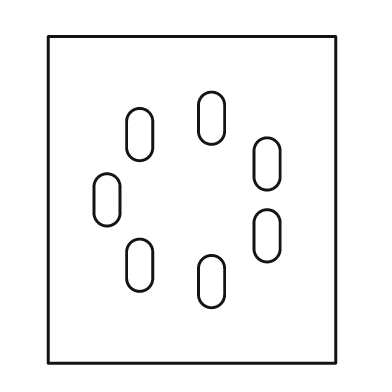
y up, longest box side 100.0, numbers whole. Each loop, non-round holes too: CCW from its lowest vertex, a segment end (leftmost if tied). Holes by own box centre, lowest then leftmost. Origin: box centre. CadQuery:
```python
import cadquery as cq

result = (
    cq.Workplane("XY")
    .moveTo(-44.0, -50.0)
    .lineTo(44.0, -50.0)
    .lineTo(44.0, 50.0)
    .lineTo(-44.0, 50.0)
    .close()
    .moveTo(2.0, -29.0)
    .threePointArc((6.0, -33.0), (10.0, -29.0))
    .lineTo(10.0, -21.0)
    .threePointArc((6.0, -17.0), (2.0, -21.0))
    .close()
    .moveTo(-20.0, -24.0)
    .threePointArc((-16.0, -28.0), (-12.0, -24.0))
    .lineTo(-12.0, -16.0)
    .threePointArc((-16.0, -12.0), (-20.0, -16.0))
    .close()
    .moveTo(19.0, -15.0)
    .threePointArc((23.0, -19.0), (27.0, -15.0))
    .lineTo(27.0, -7.0)
    .threePointArc((23.0, -3.0), (19.0, -7.0))
    .close()
    .moveTo(-30.0, -4.0)
    .threePointArc((-26.0, -8.0), (-22.0, -4.0))
    .lineTo(-22.0, 4.0)
    .threePointArc((-26.0, 8.0), (-30.0, 4.0))
    .close()
    .moveTo(19.0, 7.0)
    .threePointArc((23.0, 3.0), (27.0, 7.0))
    .lineTo(27.0, 15.0)
    .threePointArc((23.0, 19.0), (19.0, 15.0))
    .close()
    .moveTo(-20.0, 16.0)
    .threePointArc((-16.0, 12.0), (-12.0, 16.0))
    .lineTo(-12.0, 24.0)
    .threePointArc((-16.0, 28.0), (-20.0, 24.0))
    .close()
    .moveTo(2.0, 21.0)
    .threePointArc((6.0, 17.0), (10.0, 21.0))
    .lineTo(10.0, 29.0)
    .threePointArc((6.0, 33.0), (2.0, 29.0))
    .close()
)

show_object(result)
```